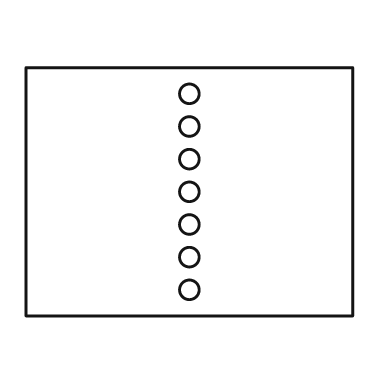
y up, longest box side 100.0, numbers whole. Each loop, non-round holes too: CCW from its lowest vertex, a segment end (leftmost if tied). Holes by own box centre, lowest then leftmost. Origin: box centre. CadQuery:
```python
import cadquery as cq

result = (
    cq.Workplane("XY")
    .moveTo(-50.0, -38.0)
    .lineTo(50.0, -38.0)
    .lineTo(50.0, 38.0)
    .lineTo(-50.0, 38.0)
    .close()
    .moveTo(0.0, -30.0)
    .circle(3.0)
    .moveTo(0.0, -20.0)
    .circle(3.0)
    .moveTo(0.0, -10.0)
    .circle(3.0)
    .moveTo(0.0, 0.0)
    .circle(3.0)
    .moveTo(0.0, 10.0)
    .circle(3.0)
    .moveTo(0.0, 20.0)
    .circle(3.0)
    .moveTo(0.0, 30.0)
    .circle(3.0)
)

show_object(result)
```